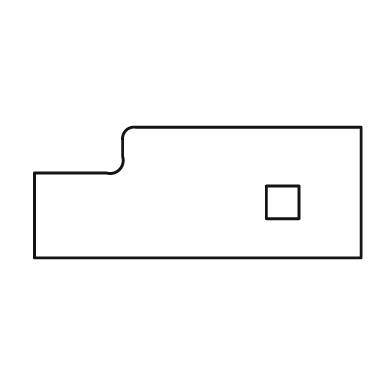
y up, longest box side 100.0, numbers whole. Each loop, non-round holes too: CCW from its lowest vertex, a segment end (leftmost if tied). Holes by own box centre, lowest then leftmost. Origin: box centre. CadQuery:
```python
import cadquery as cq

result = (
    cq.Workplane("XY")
    .moveTo(-50.0, -20.0)
    .lineTo(50.0, -20.0)
    .lineTo(50.0, 20.0)
    .lineTo(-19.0, 20.0)
    .threePointArc((-22.0, 19.0), (-23.0, 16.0))
    .lineTo(-23.0, 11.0)
    .threePointArc((-24.0, 7.0), (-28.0, 6.0))
    .lineTo(-50.0, 6.0)
    .close()
    .moveTo(21.0, -8.0)
    .lineTo(31.0, -8.0)
    .lineTo(31.0, 2.0)
    .lineTo(21.0, 2.0)
    .close()
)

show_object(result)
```